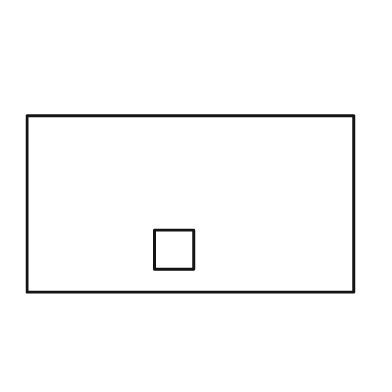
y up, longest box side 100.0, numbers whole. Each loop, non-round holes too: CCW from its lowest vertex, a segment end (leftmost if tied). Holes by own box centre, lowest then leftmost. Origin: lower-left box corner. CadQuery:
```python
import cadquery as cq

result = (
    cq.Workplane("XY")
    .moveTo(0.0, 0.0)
    .lineTo(100.0, 0.0)
    .lineTo(100.0, 54.0)
    .lineTo(0.0, 54.0)
    .close()
    .moveTo(39.0, 7.0)
    .lineTo(51.0, 7.0)
    .lineTo(51.0, 19.0)
    .lineTo(39.0, 19.0)
    .close()
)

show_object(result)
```